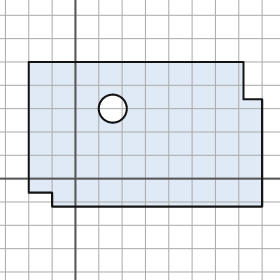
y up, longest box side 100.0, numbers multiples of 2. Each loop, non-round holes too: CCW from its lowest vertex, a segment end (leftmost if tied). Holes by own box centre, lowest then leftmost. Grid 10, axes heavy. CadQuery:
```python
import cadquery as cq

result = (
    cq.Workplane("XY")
    .moveTo(-10.0, -12.0)
    .lineTo(80.0, -12.0)
    .lineTo(80.0, 34.0)
    .lineTo(72.0, 34.0)
    .lineTo(72.0, 50.0)
    .lineTo(-20.0, 50.0)
    .lineTo(-20.0, -6.0)
    .lineTo(-10.0, -6.0)
    .close()
    .moveTo(16.0, 30.0)
    .circle(6.0)
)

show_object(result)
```